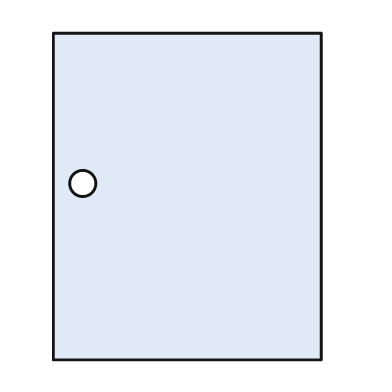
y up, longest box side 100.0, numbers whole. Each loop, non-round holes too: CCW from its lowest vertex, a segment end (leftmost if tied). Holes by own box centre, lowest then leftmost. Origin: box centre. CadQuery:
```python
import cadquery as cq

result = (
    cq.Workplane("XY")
    .moveTo(-41.0, -50.0)
    .lineTo(41.0, -50.0)
    .lineTo(41.0, 50.0)
    .lineTo(-41.0, 50.0)
    .close()
    .moveTo(-32.0, 4.0)
    .circle(4.0)
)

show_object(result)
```